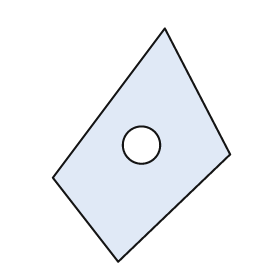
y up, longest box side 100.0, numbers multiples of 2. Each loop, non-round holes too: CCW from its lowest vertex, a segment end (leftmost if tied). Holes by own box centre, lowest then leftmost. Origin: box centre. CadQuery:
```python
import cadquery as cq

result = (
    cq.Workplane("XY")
    .moveTo(-10.0, -50.0)
    .lineTo(38.0, -4.0)
    .lineTo(10.0, 50.0)
    .lineTo(-38.0, -14.0)
    .close()
    .moveTo(0.0, 0.0)
    .circle(8.0)
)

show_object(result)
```